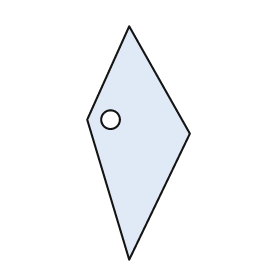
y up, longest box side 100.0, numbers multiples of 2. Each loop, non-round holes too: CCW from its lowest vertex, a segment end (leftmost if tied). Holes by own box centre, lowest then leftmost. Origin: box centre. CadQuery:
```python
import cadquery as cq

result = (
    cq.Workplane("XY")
    .moveTo(-4.0, -50.0)
    .lineTo(22.0, 4.0)
    .lineTo(-4.0, 50.0)
    .lineTo(-22.0, 10.0)
    .close()
    .moveTo(-12.0, 10.0)
    .circle(4.0)
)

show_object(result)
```